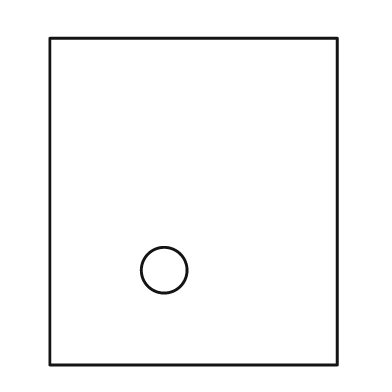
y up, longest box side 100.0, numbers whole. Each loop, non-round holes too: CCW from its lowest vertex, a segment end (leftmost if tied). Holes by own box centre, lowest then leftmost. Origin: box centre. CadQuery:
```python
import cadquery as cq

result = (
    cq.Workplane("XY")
    .moveTo(-44.0, -50.0)
    .lineTo(44.0, -50.0)
    .lineTo(44.0, 50.0)
    .lineTo(-44.0, 50.0)
    .close()
    .moveTo(-9.0, -21.0)
    .circle(7.0)
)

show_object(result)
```